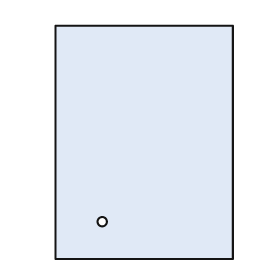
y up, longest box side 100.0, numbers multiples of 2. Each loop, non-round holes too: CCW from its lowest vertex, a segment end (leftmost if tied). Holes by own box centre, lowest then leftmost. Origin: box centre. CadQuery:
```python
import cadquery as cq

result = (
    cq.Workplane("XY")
    .moveTo(-38.0, -50.0)
    .lineTo(38.0, -50.0)
    .lineTo(38.0, 50.0)
    .lineTo(-38.0, 50.0)
    .close()
    .moveTo(-18.0, -34.0)
    .circle(2.0)
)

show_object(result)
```